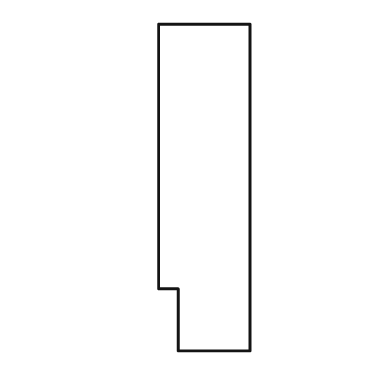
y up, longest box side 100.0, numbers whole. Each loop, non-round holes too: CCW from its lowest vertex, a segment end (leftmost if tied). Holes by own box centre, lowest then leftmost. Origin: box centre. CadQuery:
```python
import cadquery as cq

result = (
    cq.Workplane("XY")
    .moveTo(-8.0, -50.0)
    .lineTo(14.0, -50.0)
    .lineTo(14.0, 50.0)
    .lineTo(-14.0, 50.0)
    .lineTo(-14.0, -31.0)
    .lineTo(-8.0, -31.0)
    .close()
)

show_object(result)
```